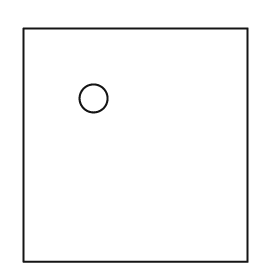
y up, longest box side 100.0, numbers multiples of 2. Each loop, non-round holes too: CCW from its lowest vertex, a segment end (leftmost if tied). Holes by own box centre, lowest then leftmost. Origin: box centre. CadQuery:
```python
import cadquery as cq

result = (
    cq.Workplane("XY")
    .moveTo(-48.0, -50.0)
    .lineTo(48.0, -50.0)
    .lineTo(48.0, 50.0)
    .lineTo(-48.0, 50.0)
    .close()
    .moveTo(-18.0, 20.0)
    .circle(6.0)
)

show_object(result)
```